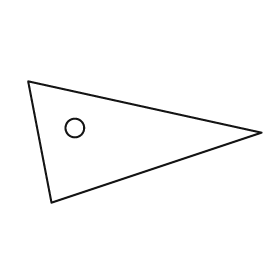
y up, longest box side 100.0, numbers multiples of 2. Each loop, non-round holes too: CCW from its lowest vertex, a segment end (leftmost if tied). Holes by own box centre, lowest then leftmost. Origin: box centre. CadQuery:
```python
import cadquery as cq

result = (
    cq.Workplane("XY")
    .moveTo(-40.0, -26.0)
    .lineTo(50.0, 4.0)
    .lineTo(-50.0, 26.0)
    .close()
    .moveTo(-30.0, 6.0)
    .circle(4.0)
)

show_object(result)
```